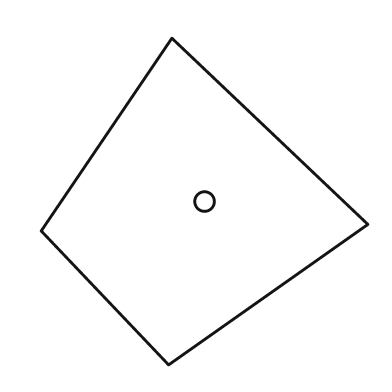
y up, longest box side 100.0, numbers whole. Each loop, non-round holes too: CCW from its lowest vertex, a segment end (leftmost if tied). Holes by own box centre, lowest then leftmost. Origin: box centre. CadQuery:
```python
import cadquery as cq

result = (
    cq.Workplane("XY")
    .moveTo(-11.0, -50.0)
    .lineTo(50.0, -7.0)
    .lineTo(-10.0, 50.0)
    .lineTo(-50.0, -9.0)
    .close()
    .moveTo(0.0, 0.0)
    .circle(3.0)
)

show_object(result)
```